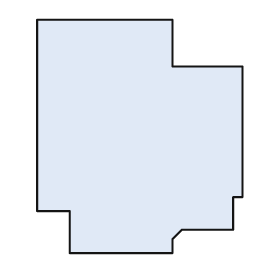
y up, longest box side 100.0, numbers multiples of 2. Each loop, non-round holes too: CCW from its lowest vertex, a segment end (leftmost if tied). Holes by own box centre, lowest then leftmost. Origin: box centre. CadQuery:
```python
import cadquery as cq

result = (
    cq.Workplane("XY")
    .moveTo(-30.0, -50.0)
    .lineTo(14.0, -50.0)
    .lineTo(14.0, -44.0)
    .lineTo(18.0, -40.0)
    .lineTo(40.0, -40.0)
    .lineTo(40.0, -26.0)
    .lineTo(44.0, -26.0)
    .lineTo(44.0, 30.0)
    .lineTo(14.0, 30.0)
    .lineTo(14.0, 50.0)
    .lineTo(-44.0, 50.0)
    .lineTo(-44.0, -32.0)
    .lineTo(-30.0, -32.0)
    .close()
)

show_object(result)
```